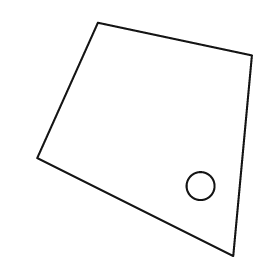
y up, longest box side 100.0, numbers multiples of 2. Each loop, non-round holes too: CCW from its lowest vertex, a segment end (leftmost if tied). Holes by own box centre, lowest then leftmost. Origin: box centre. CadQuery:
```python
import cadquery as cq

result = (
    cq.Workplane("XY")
    .moveTo(38.0, -50.0)
    .lineTo(46.0, 36.0)
    .lineTo(-20.0, 50.0)
    .lineTo(-46.0, -8.0)
    .close()
    .moveTo(24.0, -20.0)
    .circle(6.0)
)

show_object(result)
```